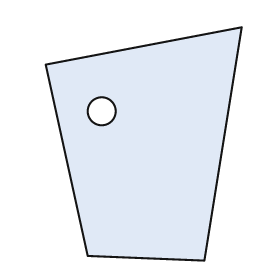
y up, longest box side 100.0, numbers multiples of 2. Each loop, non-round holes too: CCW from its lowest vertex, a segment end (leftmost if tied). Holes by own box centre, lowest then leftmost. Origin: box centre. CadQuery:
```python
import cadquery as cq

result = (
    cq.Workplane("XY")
    .moveTo(26.0, -50.0)
    .lineTo(42.0, 50.0)
    .lineTo(-42.0, 34.0)
    .lineTo(-24.0, -48.0)
    .close()
    .moveTo(-18.0, 14.0)
    .circle(6.0)
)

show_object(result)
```